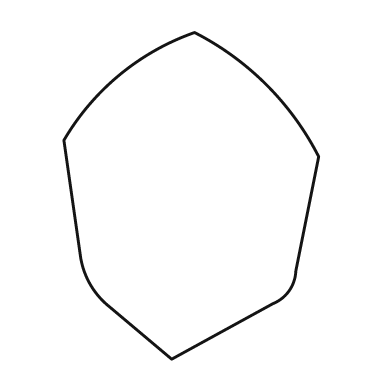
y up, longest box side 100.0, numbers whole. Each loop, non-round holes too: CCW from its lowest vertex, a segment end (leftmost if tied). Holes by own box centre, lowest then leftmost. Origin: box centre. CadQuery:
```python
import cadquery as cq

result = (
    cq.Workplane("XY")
    .moveTo(-6.0, -50.0)
    .lineTo(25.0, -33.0)
    .threePointArc((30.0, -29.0), (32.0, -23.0))
    .lineTo(39.0, 12.0)
    .threePointArc((23.0, 34.0), (1.0, 50.0))
    .threePointArc((-22.0, 37.0), (-39.0, 17.0))
    .lineTo(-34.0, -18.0)
    .threePointArc((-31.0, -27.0), (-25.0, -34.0))
    .close()
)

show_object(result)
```